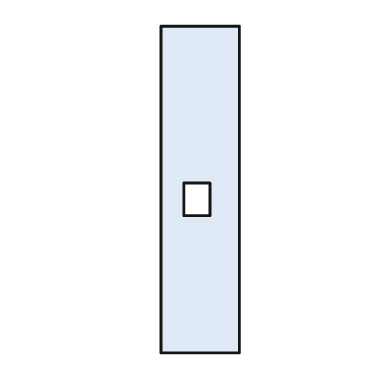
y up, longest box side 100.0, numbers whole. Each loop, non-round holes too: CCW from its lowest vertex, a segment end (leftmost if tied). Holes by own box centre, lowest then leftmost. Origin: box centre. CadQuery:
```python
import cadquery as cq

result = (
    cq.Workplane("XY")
    .moveTo(-12.0, -50.0)
    .lineTo(12.0, -50.0)
    .lineTo(12.0, 50.0)
    .lineTo(-12.0, 50.0)
    .close()
    .moveTo(-5.0, -8.0)
    .lineTo(3.0, -8.0)
    .lineTo(3.0, 2.0)
    .lineTo(-5.0, 2.0)
    .close()
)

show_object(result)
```